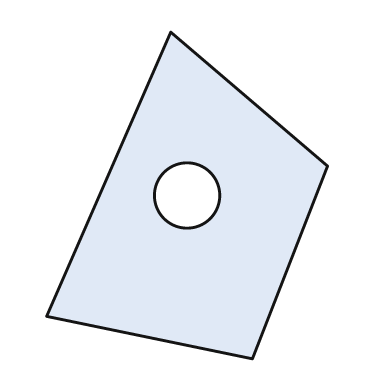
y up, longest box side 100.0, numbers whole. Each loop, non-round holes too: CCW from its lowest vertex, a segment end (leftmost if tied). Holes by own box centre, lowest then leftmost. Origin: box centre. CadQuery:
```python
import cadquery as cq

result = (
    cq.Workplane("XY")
    .moveTo(20.0, -50.0)
    .lineTo(43.0, 9.0)
    .lineTo(-5.0, 50.0)
    .lineTo(-43.0, -37.0)
    .close()
    .moveTo(0.0, 0.0)
    .circle(10.0)
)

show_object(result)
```